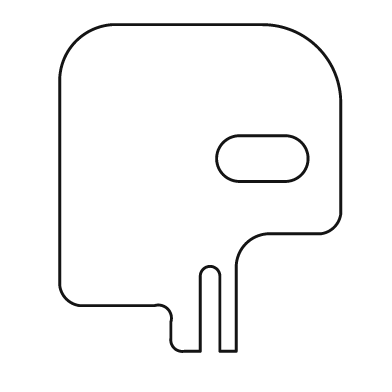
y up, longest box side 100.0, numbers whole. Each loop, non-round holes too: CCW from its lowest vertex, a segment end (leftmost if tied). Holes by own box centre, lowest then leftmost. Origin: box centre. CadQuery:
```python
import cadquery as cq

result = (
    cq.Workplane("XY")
    .moveTo(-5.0, -50.0)
    .lineTo(0.0, -50.0)
    .lineTo(0.0, -27.0)
    .threePointArc((3.0, -24.0), (6.0, -27.0))
    .lineTo(6.0, -50.0)
    .lineTo(11.0, -50.0)
    .lineTo(11.0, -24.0)
    .threePointArc((14.0, -17.0), (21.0, -14.0))
    .lineTo(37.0, -14.0)
    .threePointArc((41.0, -12.0), (43.0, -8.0))
    .lineTo(43.0, 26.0)
    .threePointArc((36.0, 43.0), (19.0, 50.0))
    .lineTo(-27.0, 50.0)
    .threePointArc((-38.0, 45.0), (-43.0, 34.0))
    .lineTo(-43.0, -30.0)
    .threePointArc((-41.0, -34.0), (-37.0, -36.0))
    .lineTo(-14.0, -36.0)
    .threePointArc((-10.0, -37.0), (-9.0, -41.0))
    .lineTo(-9.0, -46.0)
    .threePointArc((-8.0, -49.0), (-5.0, -50.0))
    .close()
    .moveTo(12.0, 2.0)
    .lineTo(26.0, 2.0)
    .threePointArc((33.0, 9.0), (26.0, 16.0))
    .lineTo(12.0, 16.0)
    .threePointArc((5.0, 9.0), (12.0, 2.0))
    .close()
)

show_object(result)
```